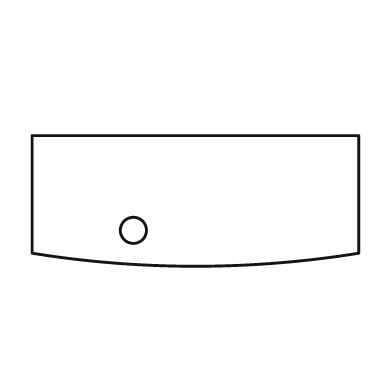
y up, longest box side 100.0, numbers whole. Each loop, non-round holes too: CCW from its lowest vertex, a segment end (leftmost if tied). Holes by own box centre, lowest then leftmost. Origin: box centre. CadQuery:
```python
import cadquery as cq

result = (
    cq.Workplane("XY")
    .moveTo(-50.0, -16.0)
    .threePointArc((0.0, -20.0), (50.0, -16.0))
    .lineTo(50.0, 20.0)
    .lineTo(-50.0, 20.0)
    .close()
    .moveTo(-19.0, -9.0)
    .circle(4.0)
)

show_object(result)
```